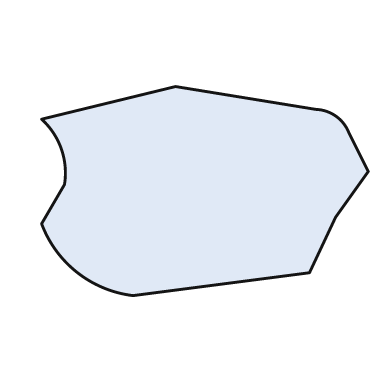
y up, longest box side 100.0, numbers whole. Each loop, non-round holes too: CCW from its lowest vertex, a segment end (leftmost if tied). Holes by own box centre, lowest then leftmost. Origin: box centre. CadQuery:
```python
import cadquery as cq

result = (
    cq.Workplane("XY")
    .moveTo(-22.0, -32.0)
    .lineTo(32.0, -25.0)
    .lineTo(40.0, -8.0)
    .lineTo(50.0, 6.0)
    .lineTo(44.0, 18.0)
    .threePointArc((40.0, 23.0), (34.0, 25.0))
    .lineTo(-9.0, 32.0)
    .lineTo(-50.0, 22.0)
    .threePointArc((-44.0, 13.0), (-43.0, 2.0))
    .lineTo(-50.0, -10.0)
    .threePointArc((-39.0, -25.0), (-22.0, -32.0))
    .close()
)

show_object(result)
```